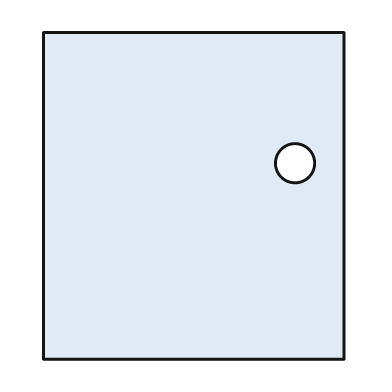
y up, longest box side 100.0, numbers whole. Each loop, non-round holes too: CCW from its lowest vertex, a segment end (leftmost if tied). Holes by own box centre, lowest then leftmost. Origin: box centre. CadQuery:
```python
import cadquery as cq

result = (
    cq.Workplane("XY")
    .moveTo(-46.0, -50.0)
    .lineTo(46.0, -50.0)
    .lineTo(46.0, 50.0)
    .lineTo(-46.0, 50.0)
    .close()
    .moveTo(31.0, 10.0)
    .circle(6.0)
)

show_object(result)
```